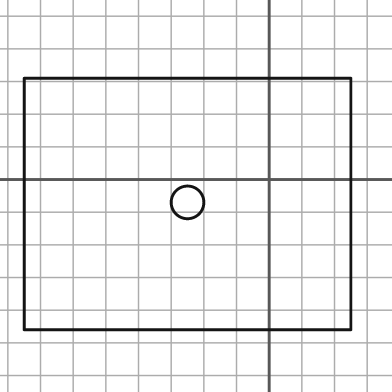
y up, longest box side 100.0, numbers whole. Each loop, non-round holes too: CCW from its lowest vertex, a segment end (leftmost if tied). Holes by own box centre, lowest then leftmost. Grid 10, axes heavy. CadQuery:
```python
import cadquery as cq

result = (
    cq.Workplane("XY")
    .moveTo(-75.0, -46.0)
    .lineTo(25.0, -46.0)
    .lineTo(25.0, 31.0)
    .lineTo(-75.0, 31.0)
    .close()
    .moveTo(-25.0, -7.0)
    .circle(5.0)
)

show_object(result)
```